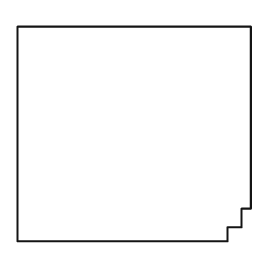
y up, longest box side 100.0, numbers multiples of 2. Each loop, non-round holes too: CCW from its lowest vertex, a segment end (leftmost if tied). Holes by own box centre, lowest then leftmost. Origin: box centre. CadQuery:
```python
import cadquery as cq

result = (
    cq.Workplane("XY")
    .moveTo(-50.0, -46.0)
    .lineTo(40.0, -46.0)
    .lineTo(40.0, -40.0)
    .lineTo(46.0, -40.0)
    .lineTo(46.0, -32.0)
    .lineTo(50.0, -32.0)
    .lineTo(50.0, 46.0)
    .lineTo(-50.0, 46.0)
    .close()
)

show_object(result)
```